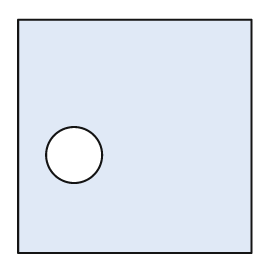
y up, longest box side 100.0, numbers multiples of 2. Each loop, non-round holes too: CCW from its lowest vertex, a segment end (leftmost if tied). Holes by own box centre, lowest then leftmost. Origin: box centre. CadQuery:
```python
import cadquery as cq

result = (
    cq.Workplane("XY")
    .moveTo(-50.0, -50.0)
    .lineTo(50.0, -50.0)
    .lineTo(50.0, 50.0)
    .lineTo(-50.0, 50.0)
    .close()
    .moveTo(-26.0, -8.0)
    .circle(12.0)
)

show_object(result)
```